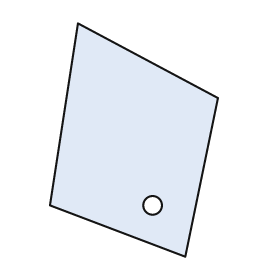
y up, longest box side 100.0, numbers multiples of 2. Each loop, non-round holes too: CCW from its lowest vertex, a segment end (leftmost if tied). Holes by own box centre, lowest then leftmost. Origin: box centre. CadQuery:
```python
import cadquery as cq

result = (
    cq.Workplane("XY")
    .moveTo(22.0, -50.0)
    .lineTo(36.0, 18.0)
    .lineTo(-24.0, 50.0)
    .lineTo(-36.0, -28.0)
    .close()
    .moveTo(8.0, -28.0)
    .circle(4.0)
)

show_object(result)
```